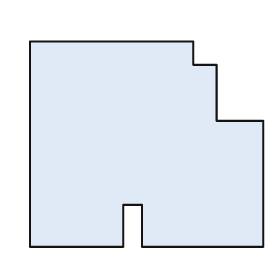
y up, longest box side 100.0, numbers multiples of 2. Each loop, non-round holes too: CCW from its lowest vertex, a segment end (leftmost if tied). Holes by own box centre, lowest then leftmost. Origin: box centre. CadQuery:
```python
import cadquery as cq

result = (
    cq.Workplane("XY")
    .moveTo(-50.0, -44.0)
    .lineTo(-10.0, -44.0)
    .lineTo(-10.0, -26.0)
    .lineTo(-2.0, -26.0)
    .lineTo(-2.0, -44.0)
    .lineTo(50.0, -44.0)
    .lineTo(50.0, 10.0)
    .lineTo(30.0, 10.0)
    .lineTo(30.0, 34.0)
    .lineTo(20.0, 34.0)
    .lineTo(20.0, 44.0)
    .lineTo(-50.0, 44.0)
    .close()
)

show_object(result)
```